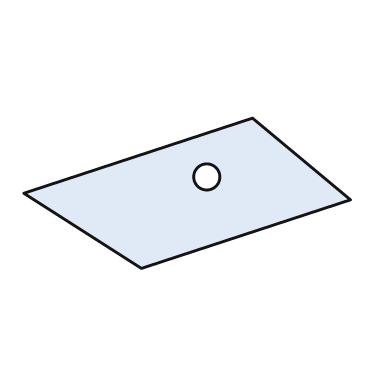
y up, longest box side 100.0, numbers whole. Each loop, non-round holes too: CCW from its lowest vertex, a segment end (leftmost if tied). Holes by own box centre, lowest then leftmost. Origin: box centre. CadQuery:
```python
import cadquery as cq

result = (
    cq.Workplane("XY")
    .moveTo(-14.0, -23.0)
    .lineTo(50.0, -2.0)
    .lineTo(20.0, 23.0)
    .lineTo(-50.0, 0.0)
    .close()
    .moveTo(6.0, 5.0)
    .circle(4.0)
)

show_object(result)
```